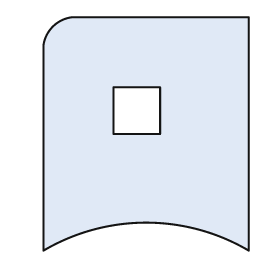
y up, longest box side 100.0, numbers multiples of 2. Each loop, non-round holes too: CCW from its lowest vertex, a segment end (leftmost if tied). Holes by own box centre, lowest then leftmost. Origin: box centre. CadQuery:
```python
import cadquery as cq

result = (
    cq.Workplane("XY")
    .moveTo(-44.0, -50.0)
    .threePointArc((0.0, -38.0), (44.0, -50.0))
    .lineTo(44.0, 50.0)
    .lineTo(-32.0, 50.0)
    .threePointArc((-40.0, 46.0), (-44.0, 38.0))
    .close()
    .moveTo(-14.0, 0.0)
    .lineTo(6.0, 0.0)
    .lineTo(6.0, 20.0)
    .lineTo(-14.0, 20.0)
    .close()
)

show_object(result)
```